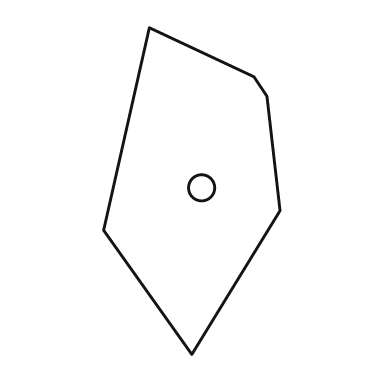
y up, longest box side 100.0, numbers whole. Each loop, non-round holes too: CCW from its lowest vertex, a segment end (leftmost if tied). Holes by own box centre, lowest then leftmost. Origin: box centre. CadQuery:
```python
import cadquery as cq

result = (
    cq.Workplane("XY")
    .moveTo(0.0, -50.0)
    .lineTo(27.0, -6.0)
    .lineTo(23.0, 29.0)
    .lineTo(19.0, 35.0)
    .lineTo(-13.0, 50.0)
    .lineTo(-27.0, -12.0)
    .close()
    .moveTo(3.0, 1.0)
    .circle(4.0)
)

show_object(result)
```